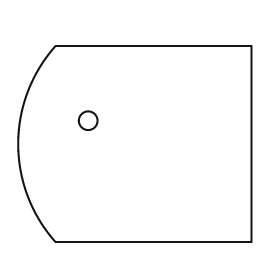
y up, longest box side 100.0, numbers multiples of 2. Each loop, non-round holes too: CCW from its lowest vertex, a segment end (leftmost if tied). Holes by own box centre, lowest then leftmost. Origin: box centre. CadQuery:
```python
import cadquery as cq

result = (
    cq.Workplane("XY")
    .moveTo(-34.0, -42.0)
    .lineTo(50.0, -42.0)
    .lineTo(50.0, 42.0)
    .lineTo(-34.0, 42.0)
    .threePointArc((-50.0, 0.0), (-34.0, -42.0))
    .close()
    .moveTo(-20.0, 10.0)
    .circle(4.0)
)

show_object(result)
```